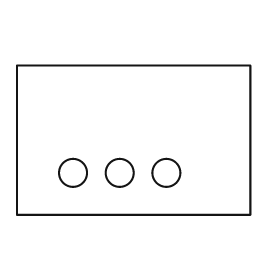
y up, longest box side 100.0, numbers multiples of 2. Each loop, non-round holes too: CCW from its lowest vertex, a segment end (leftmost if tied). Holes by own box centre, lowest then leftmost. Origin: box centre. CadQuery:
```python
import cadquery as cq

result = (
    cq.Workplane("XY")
    .moveTo(-50.0, -32.0)
    .lineTo(50.0, -32.0)
    .lineTo(50.0, 32.0)
    .lineTo(-50.0, 32.0)
    .close()
    .moveTo(-26.0, -14.0)
    .circle(6.0)
    .moveTo(-6.0, -14.0)
    .circle(6.0)
    .moveTo(14.0, -14.0)
    .circle(6.0)
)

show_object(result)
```